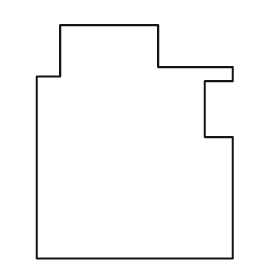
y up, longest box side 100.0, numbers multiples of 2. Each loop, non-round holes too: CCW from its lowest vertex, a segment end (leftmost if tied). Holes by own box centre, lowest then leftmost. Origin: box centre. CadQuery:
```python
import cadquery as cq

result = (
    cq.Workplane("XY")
    .moveTo(-42.0, -50.0)
    .lineTo(42.0, -50.0)
    .lineTo(42.0, 2.0)
    .lineTo(30.0, 2.0)
    .lineTo(30.0, 26.0)
    .lineTo(42.0, 26.0)
    .lineTo(42.0, 32.0)
    .lineTo(10.0, 32.0)
    .lineTo(10.0, 50.0)
    .lineTo(-32.0, 50.0)
    .lineTo(-32.0, 28.0)
    .lineTo(-42.0, 28.0)
    .close()
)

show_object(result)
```